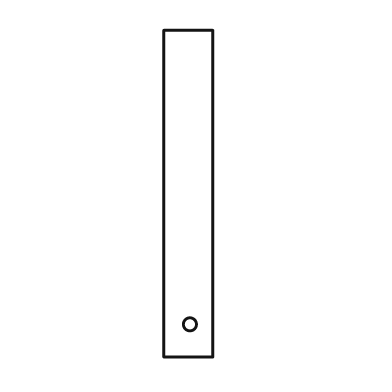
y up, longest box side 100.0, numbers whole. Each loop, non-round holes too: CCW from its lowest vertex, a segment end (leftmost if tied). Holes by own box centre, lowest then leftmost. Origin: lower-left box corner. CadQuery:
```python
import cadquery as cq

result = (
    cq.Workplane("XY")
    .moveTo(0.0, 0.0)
    .lineTo(15.0, 0.0)
    .lineTo(15.0, 100.0)
    .lineTo(0.0, 100.0)
    .close()
    .moveTo(8.0, 10.0)
    .circle(2.0)
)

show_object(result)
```